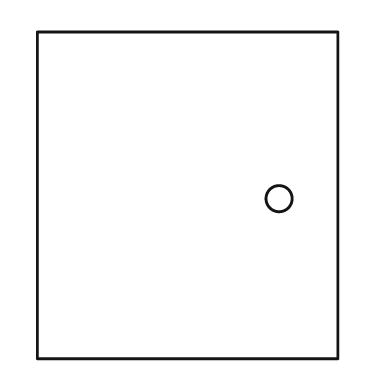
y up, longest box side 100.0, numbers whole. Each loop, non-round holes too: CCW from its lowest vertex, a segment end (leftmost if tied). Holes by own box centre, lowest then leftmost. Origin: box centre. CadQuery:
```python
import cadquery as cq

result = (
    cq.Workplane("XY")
    .moveTo(-46.0, -50.0)
    .lineTo(46.0, -50.0)
    .lineTo(46.0, 50.0)
    .lineTo(-46.0, 50.0)
    .close()
    .moveTo(28.0, -1.0)
    .circle(4.0)
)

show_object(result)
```